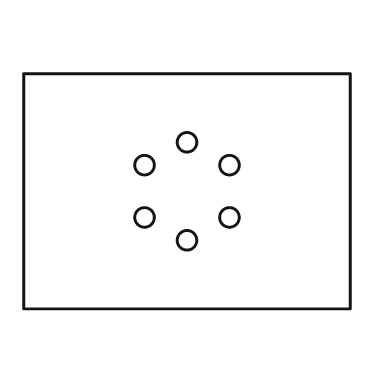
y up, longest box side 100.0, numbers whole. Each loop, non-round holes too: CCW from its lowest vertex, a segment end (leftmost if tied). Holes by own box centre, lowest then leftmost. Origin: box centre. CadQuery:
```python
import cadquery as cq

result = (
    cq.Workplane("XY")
    .moveTo(-50.0, -36.0)
    .lineTo(50.0, -36.0)
    .lineTo(50.0, 36.0)
    .lineTo(-50.0, 36.0)
    .close()
    .moveTo(0.0, -15.0)
    .circle(3.0)
    .moveTo(-13.0, -8.0)
    .circle(3.0)
    .moveTo(13.0, -8.0)
    .circle(3.0)
    .moveTo(-13.0, 8.0)
    .circle(3.0)
    .moveTo(13.0, 8.0)
    .circle(3.0)
    .moveTo(0.0, 15.0)
    .circle(3.0)
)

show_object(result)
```